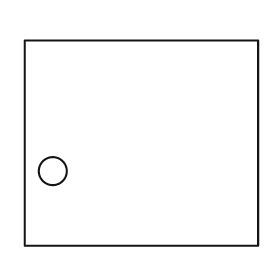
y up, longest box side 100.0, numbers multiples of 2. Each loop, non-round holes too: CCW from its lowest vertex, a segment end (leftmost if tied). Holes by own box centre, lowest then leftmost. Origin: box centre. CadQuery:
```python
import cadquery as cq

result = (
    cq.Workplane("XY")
    .moveTo(-50.0, -44.0)
    .lineTo(50.0, -44.0)
    .lineTo(50.0, 44.0)
    .lineTo(-50.0, 44.0)
    .close()
    .moveTo(-38.0, -12.0)
    .circle(6.0)
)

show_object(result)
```